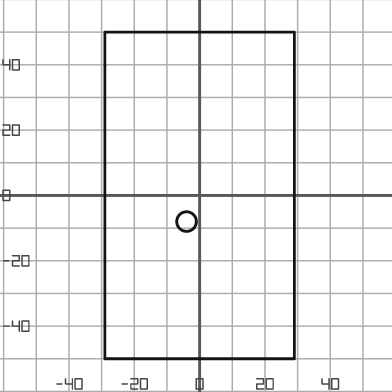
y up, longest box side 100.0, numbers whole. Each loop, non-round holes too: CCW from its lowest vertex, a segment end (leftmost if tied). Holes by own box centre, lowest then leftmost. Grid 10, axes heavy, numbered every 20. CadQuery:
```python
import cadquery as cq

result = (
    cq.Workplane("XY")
    .moveTo(-29.0, -50.0)
    .lineTo(29.0, -50.0)
    .lineTo(29.0, 50.0)
    .lineTo(-29.0, 50.0)
    .close()
    .moveTo(-4.0, -8.0)
    .circle(3.0)
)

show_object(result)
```